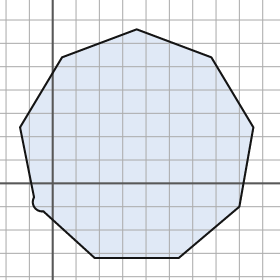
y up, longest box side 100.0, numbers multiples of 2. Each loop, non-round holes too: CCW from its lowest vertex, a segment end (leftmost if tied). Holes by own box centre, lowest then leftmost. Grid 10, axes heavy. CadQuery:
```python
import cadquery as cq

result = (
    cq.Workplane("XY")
    .moveTo(18.0, -32.0)
    .lineTo(54.0, -32.0)
    .lineTo(80.0, -10.0)
    .lineTo(86.0, 24.0)
    .lineTo(68.0, 54.0)
    .lineTo(36.0, 66.0)
    .lineTo(4.0, 54.0)
    .lineTo(-14.0, 24.0)
    .lineTo(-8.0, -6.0)
    .threePointArc((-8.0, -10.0), (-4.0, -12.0))
    .close()
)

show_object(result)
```